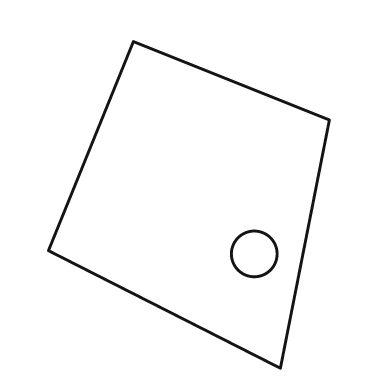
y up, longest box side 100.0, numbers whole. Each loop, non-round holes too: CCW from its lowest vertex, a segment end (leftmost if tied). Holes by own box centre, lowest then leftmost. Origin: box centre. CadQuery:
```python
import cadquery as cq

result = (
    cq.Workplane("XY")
    .moveTo(28.0, -50.0)
    .lineTo(43.0, 26.0)
    .lineTo(-17.0, 50.0)
    .lineTo(-43.0, -14.0)
    .close()
    .moveTo(20.0, -15.0)
    .circle(7.0)
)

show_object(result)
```